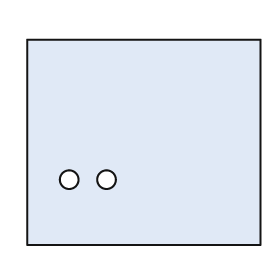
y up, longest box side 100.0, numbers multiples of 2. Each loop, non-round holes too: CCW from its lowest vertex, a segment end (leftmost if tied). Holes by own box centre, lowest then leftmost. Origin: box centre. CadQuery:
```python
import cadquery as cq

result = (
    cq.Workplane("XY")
    .moveTo(-50.0, -44.0)
    .lineTo(50.0, -44.0)
    .lineTo(50.0, 44.0)
    .lineTo(-50.0, 44.0)
    .close()
    .moveTo(-32.0, -16.0)
    .circle(4.0)
    .moveTo(-16.0, -16.0)
    .circle(4.0)
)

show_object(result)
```